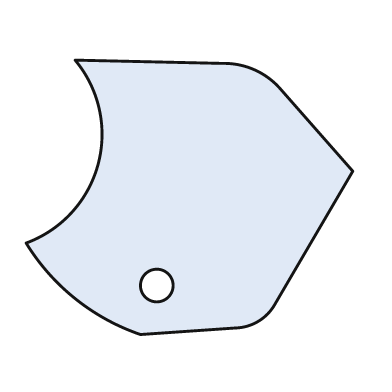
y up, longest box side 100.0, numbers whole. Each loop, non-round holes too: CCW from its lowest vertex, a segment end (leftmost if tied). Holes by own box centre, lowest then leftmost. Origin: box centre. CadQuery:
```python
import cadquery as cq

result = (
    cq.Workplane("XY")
    .moveTo(-15.0, -42.0)
    .lineTo(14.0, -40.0)
    .threePointArc((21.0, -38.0), (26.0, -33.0))
    .lineTo(50.0, 8.0)
    .lineTo(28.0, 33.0)
    .threePointArc((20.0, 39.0), (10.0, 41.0))
    .lineTo(-35.0, 42.0)
    .threePointArc((-28.0, 10.0), (-50.0, -14.0))
    .threePointArc((-35.0, -31.0), (-15.0, -42.0))
    .close()
    .moveTo(-10.0, -27.0)
    .circle(5.0)
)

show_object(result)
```